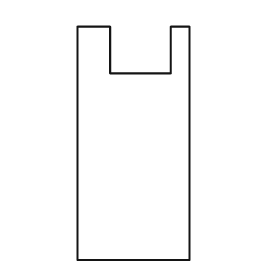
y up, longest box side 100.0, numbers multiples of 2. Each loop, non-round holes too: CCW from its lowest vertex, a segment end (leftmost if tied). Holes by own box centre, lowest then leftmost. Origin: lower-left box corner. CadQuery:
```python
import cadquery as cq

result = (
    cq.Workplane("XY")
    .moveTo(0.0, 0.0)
    .lineTo(48.0, 0.0)
    .lineTo(48.0, 100.0)
    .lineTo(40.0, 100.0)
    .lineTo(40.0, 80.0)
    .lineTo(14.0, 80.0)
    .lineTo(14.0, 100.0)
    .lineTo(0.0, 100.0)
    .close()
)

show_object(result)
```